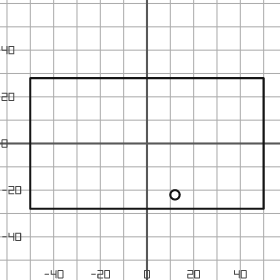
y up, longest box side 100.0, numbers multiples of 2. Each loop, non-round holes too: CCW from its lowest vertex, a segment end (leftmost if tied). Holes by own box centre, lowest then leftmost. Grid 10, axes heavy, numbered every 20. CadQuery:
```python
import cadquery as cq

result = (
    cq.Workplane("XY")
    .moveTo(-50.0, -28.0)
    .lineTo(50.0, -28.0)
    .lineTo(50.0, 28.0)
    .lineTo(-50.0, 28.0)
    .close()
    .moveTo(12.0, -22.0)
    .circle(2.0)
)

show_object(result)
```